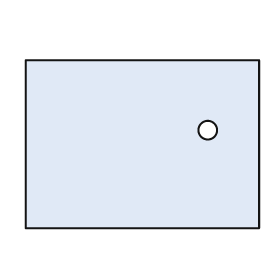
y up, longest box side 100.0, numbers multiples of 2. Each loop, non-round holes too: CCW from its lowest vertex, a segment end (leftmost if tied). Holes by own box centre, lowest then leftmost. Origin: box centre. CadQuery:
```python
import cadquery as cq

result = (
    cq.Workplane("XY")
    .moveTo(-50.0, -36.0)
    .lineTo(50.0, -36.0)
    .lineTo(50.0, 36.0)
    .lineTo(-50.0, 36.0)
    .close()
    .moveTo(28.0, 6.0)
    .circle(4.0)
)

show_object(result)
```